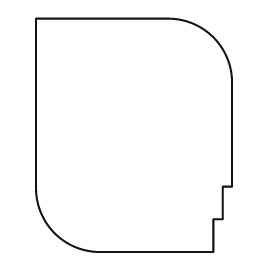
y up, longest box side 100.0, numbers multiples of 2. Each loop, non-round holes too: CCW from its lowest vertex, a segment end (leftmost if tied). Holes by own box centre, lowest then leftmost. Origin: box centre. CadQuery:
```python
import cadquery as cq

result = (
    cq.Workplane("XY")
    .moveTo(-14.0, -50.0)
    .lineTo(34.0, -50.0)
    .lineTo(34.0, -36.0)
    .lineTo(38.0, -36.0)
    .lineTo(38.0, -22.0)
    .lineTo(42.0, -22.0)
    .lineTo(42.0, 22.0)
    .threePointArc((34.0, 42.0), (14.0, 50.0))
    .lineTo(-42.0, 50.0)
    .lineTo(-42.0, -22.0)
    .threePointArc((-34.0, -42.0), (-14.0, -50.0))
    .close()
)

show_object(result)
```